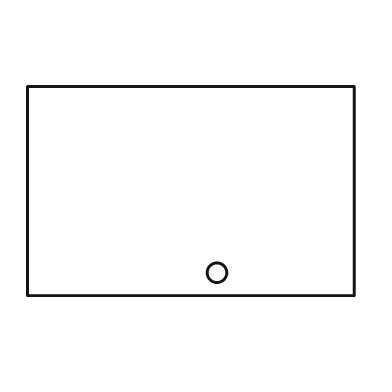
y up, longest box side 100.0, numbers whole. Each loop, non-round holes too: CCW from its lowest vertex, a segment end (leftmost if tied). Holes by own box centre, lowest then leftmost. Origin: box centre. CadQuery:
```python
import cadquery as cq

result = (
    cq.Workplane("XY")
    .moveTo(-50.0, -32.0)
    .lineTo(50.0, -32.0)
    .lineTo(50.0, 32.0)
    .lineTo(-50.0, 32.0)
    .close()
    .moveTo(8.0, -25.0)
    .circle(3.0)
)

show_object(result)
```